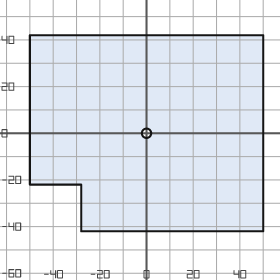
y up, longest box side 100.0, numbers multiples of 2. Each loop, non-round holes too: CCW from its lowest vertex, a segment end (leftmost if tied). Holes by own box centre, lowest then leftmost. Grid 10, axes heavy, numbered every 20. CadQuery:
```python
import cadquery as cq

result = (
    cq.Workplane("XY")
    .moveTo(-28.0, -42.0)
    .lineTo(50.0, -42.0)
    .lineTo(50.0, 42.0)
    .lineTo(-50.0, 42.0)
    .lineTo(-50.0, -22.0)
    .lineTo(-28.0, -22.0)
    .close()
    .moveTo(0.0, 0.0)
    .circle(2.0)
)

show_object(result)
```